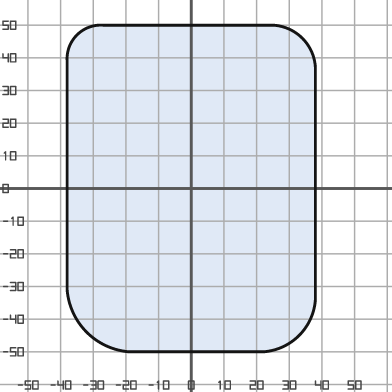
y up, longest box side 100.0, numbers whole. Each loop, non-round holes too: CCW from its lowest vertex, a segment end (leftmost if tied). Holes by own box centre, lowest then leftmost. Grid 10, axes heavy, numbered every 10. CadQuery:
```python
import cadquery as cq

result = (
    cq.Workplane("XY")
    .moveTo(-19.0, -50.0)
    .lineTo(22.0, -50.0)
    .threePointArc((33.0, -45.0), (38.0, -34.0))
    .lineTo(38.0, 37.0)
    .threePointArc((34.0, 46.0), (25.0, 50.0))
    .lineTo(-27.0, 50.0)
    .threePointArc((-35.0, 47.0), (-38.0, 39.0))
    .lineTo(-38.0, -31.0)
    .threePointArc((-32.0, -44.0), (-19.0, -50.0))
    .close()
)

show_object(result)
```